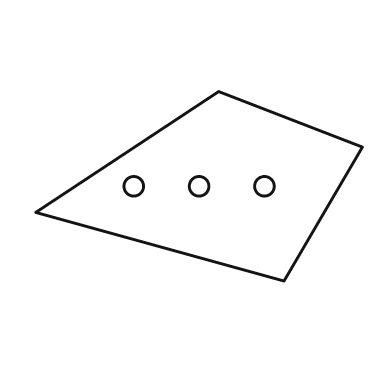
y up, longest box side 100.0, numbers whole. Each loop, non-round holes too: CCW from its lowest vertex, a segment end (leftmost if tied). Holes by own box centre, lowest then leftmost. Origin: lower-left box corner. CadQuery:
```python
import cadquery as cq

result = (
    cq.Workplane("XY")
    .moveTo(76.0, 0.0)
    .lineTo(100.0, 41.0)
    .lineTo(56.0, 58.0)
    .lineTo(0.0, 21.0)
    .close()
    .moveTo(30.0, 29.0)
    .circle(3.0)
    .moveTo(50.0, 29.0)
    .circle(3.0)
    .moveTo(70.0, 29.0)
    .circle(3.0)
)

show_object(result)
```